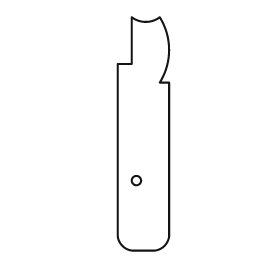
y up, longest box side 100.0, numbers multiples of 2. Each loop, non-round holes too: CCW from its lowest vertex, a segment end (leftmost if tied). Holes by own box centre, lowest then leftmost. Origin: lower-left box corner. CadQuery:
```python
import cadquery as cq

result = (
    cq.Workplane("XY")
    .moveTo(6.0, 0.0)
    .lineTo(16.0, 0.0)
    .threePointArc((20.0, 2.0), (22.0, 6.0))
    .lineTo(22.0, 72.0)
    .lineTo(18.0, 72.0)
    .threePointArc((22.0, 86.0), (18.0, 100.0))
    .threePointArc((12.0, 98.0), (6.0, 100.0))
    .lineTo(6.0, 80.0)
    .lineTo(0.0, 80.0)
    .lineTo(0.0, 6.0)
    .threePointArc((2.0, 2.0), (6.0, 0.0))
    .close()
    .moveTo(8.0, 30.0)
    .circle(2.0)
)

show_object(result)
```